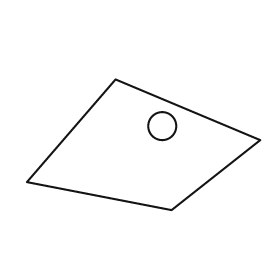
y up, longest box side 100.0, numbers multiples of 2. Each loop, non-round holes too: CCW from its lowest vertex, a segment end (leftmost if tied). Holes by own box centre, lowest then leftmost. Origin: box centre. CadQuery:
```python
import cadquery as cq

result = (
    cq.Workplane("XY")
    .moveTo(12.0, -28.0)
    .lineTo(50.0, 2.0)
    .lineTo(-12.0, 28.0)
    .lineTo(-50.0, -16.0)
    .close()
    .moveTo(8.0, 8.0)
    .circle(6.0)
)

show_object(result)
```